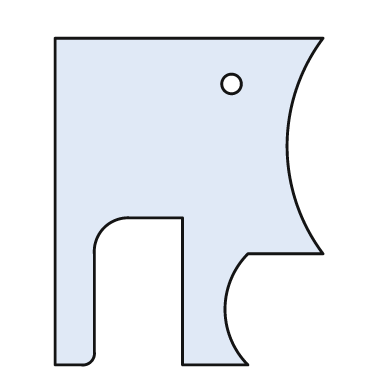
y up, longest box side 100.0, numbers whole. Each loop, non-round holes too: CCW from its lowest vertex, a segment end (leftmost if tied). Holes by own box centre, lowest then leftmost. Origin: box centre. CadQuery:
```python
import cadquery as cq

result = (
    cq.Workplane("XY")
    .moveTo(-41.0, -50.0)
    .lineTo(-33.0, -50.0)
    .threePointArc((-30.0, -49.0), (-29.0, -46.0))
    .lineTo(-29.0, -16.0)
    .threePointArc((-26.0, -8.0), (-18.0, -5.0))
    .lineTo(-2.0, -5.0)
    .lineTo(-2.0, -50.0)
    .lineTo(18.0, -50.0)
    .threePointArc((11.0, -33.0), (18.0, -16.0))
    .lineTo(41.0, -16.0)
    .threePointArc((30.0, 17.0), (41.0, 50.0))
    .lineTo(-41.0, 50.0)
    .close()
    .moveTo(13.0, 36.0)
    .circle(3.0)
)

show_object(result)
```